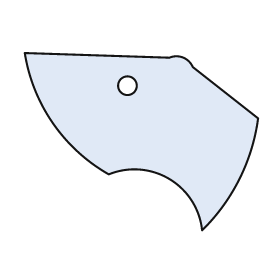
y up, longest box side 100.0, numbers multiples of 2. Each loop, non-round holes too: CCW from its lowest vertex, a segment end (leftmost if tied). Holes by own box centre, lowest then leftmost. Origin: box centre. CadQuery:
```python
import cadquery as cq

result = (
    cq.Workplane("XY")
    .moveTo(26.0, -38.0)
    .threePointArc((42.0, -16.0), (50.0, 10.0))
    .lineTo(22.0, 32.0)
    .threePointArc((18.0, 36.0), (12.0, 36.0))
    .lineTo(-50.0, 38.0)
    .threePointArc((-38.0, 8.0), (-14.0, -14.0))
    .threePointArc((12.0, -16.0), (26.0, -38.0))
    .close()
    .moveTo(-6.0, 24.0)
    .circle(4.0)
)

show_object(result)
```